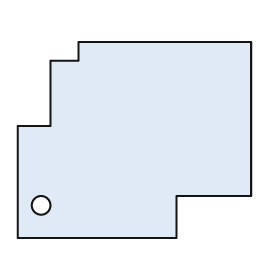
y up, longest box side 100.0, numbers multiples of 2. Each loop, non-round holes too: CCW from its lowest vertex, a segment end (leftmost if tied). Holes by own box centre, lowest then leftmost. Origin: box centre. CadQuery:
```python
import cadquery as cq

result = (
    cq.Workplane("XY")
    .moveTo(-50.0, -42.0)
    .lineTo(18.0, -42.0)
    .lineTo(18.0, -24.0)
    .lineTo(50.0, -24.0)
    .lineTo(50.0, 42.0)
    .lineTo(-24.0, 42.0)
    .lineTo(-24.0, 34.0)
    .lineTo(-36.0, 34.0)
    .lineTo(-36.0, 6.0)
    .lineTo(-50.0, 6.0)
    .close()
    .moveTo(-40.0, -28.0)
    .circle(4.0)
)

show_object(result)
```